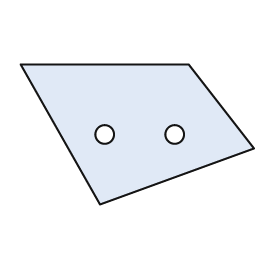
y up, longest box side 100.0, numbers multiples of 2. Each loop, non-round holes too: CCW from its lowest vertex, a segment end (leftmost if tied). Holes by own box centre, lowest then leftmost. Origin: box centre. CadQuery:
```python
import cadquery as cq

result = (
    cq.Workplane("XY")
    .moveTo(-16.0, -30.0)
    .lineTo(50.0, -6.0)
    .lineTo(22.0, 30.0)
    .lineTo(-50.0, 30.0)
    .close()
    .moveTo(-14.0, 0.0)
    .circle(4.0)
    .moveTo(16.0, 0.0)
    .circle(4.0)
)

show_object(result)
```